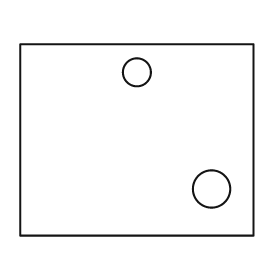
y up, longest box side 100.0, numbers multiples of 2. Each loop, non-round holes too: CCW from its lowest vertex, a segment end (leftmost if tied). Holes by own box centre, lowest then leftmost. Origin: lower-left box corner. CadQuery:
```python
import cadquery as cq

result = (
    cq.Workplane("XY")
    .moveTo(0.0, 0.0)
    .lineTo(100.0, 0.0)
    .lineTo(100.0, 82.0)
    .lineTo(0.0, 82.0)
    .close()
    .moveTo(82.0, 20.0)
    .circle(8.0)
    .moveTo(50.0, 70.0)
    .circle(6.0)
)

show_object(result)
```